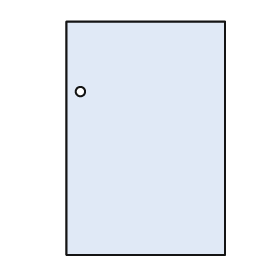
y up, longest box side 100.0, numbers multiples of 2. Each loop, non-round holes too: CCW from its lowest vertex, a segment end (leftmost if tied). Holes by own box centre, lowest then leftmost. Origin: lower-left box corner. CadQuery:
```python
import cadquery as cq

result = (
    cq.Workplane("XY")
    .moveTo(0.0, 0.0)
    .lineTo(68.0, 0.0)
    .lineTo(68.0, 100.0)
    .lineTo(0.0, 100.0)
    .close()
    .moveTo(6.0, 70.0)
    .circle(2.0)
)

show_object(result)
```